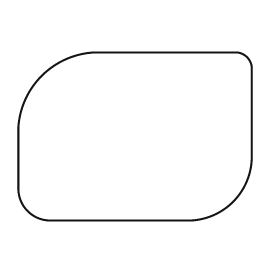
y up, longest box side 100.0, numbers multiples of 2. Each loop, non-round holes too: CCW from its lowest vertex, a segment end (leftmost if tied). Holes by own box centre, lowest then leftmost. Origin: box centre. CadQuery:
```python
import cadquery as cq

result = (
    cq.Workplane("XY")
    .moveTo(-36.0, -36.0)
    .lineTo(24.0, -36.0)
    .threePointArc((42.0, -28.0), (50.0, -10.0))
    .lineTo(50.0, 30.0)
    .threePointArc((48.0, 34.0), (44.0, 36.0))
    .lineTo(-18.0, 36.0)
    .threePointArc((-40.0, 26.0), (-50.0, 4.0))
    .lineTo(-50.0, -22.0)
    .threePointArc((-46.0, -32.0), (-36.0, -36.0))
    .close()
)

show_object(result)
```